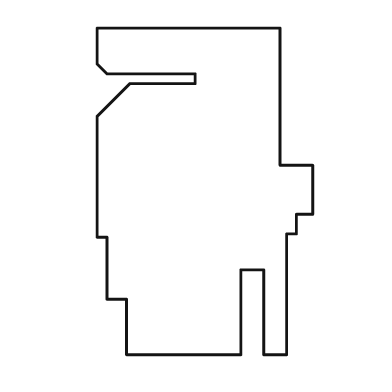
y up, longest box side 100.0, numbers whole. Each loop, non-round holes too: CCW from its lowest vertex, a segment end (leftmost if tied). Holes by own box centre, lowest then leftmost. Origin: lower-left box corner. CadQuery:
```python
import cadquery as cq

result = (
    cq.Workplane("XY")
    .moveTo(9.0, 0.0)
    .lineTo(44.0, 0.0)
    .lineTo(44.0, 26.0)
    .lineTo(51.0, 26.0)
    .lineTo(51.0, 0.0)
    .lineTo(58.0, 0.0)
    .lineTo(58.0, 37.0)
    .lineTo(61.0, 37.0)
    .lineTo(61.0, 43.0)
    .lineTo(66.0, 43.0)
    .lineTo(66.0, 58.0)
    .lineTo(56.0, 58.0)
    .lineTo(56.0, 100.0)
    .lineTo(0.0, 100.0)
    .lineTo(0.0, 89.0)
    .lineTo(3.0, 86.0)
    .lineTo(30.0, 86.0)
    .lineTo(30.0, 83.0)
    .lineTo(10.0, 83.0)
    .lineTo(0.0, 73.0)
    .lineTo(0.0, 36.0)
    .lineTo(3.0, 36.0)
    .lineTo(3.0, 17.0)
    .lineTo(9.0, 17.0)
    .close()
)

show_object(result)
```